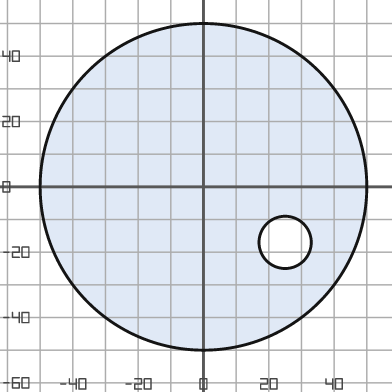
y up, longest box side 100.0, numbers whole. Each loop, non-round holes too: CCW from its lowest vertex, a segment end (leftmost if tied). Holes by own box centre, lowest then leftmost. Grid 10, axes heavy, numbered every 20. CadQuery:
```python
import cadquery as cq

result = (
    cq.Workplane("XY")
    .moveTo(0.0, 0.0)
    .circle(50.0)
    .moveTo(25.0, -17.0)
    .circle(8.0)
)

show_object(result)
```